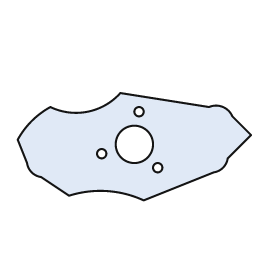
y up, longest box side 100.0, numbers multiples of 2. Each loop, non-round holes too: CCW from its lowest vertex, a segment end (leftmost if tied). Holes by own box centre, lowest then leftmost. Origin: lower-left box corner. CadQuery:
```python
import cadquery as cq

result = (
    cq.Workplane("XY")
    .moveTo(54.0, 0.0)
    .lineTo(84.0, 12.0)
    .threePointArc((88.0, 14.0), (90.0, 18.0))
    .lineTo(100.0, 28.0)
    .lineTo(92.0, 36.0)
    .threePointArc((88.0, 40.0), (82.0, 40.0))
    .lineTo(44.0, 46.0)
    .threePointArc((30.0, 38.0), (14.0, 40.0))
    .threePointArc((6.0, 34.0), (0.0, 26.0))
    .lineTo(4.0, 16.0)
    .threePointArc((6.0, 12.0), (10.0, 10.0))
    .lineTo(22.0, 2.0)
    .threePointArc((38.0, 4.0), (54.0, 0.0))
    .close()
    .moveTo(60.0, 14.0)
    .circle(2.0)
    .moveTo(36.0, 20.0)
    .circle(2.0)
    .moveTo(50.0, 24.0)
    .circle(8.0)
    .moveTo(52.0, 38.0)
    .circle(2.0)
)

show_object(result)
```